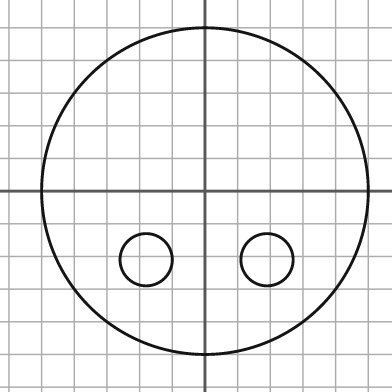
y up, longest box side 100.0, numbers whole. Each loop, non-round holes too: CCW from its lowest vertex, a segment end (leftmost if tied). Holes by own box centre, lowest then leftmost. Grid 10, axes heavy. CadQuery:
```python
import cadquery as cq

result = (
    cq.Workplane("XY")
    .moveTo(0.0, 0.0)
    .circle(50.0)
    .moveTo(-18.0, -21.0)
    .circle(8.0)
    .moveTo(19.0, -21.0)
    .circle(8.0)
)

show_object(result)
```